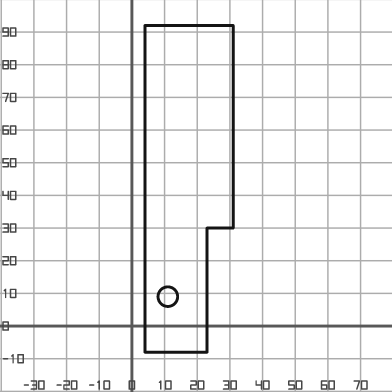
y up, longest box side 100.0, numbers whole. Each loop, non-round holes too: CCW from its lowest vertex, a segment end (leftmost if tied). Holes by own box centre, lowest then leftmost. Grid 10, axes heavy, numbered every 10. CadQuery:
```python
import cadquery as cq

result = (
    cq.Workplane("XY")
    .moveTo(4.0, -8.0)
    .lineTo(23.0, -8.0)
    .lineTo(23.0, 30.0)
    .lineTo(31.0, 30.0)
    .lineTo(31.0, 92.0)
    .lineTo(4.0, 92.0)
    .close()
    .moveTo(11.0, 9.0)
    .circle(3.0)
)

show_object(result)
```